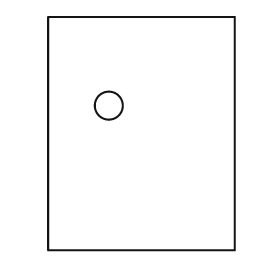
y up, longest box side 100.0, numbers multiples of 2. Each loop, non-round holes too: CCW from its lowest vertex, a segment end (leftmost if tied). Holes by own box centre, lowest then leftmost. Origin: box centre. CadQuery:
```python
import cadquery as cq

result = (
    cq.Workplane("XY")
    .moveTo(-40.0, -50.0)
    .lineTo(40.0, -50.0)
    .lineTo(40.0, 50.0)
    .lineTo(-40.0, 50.0)
    .close()
    .moveTo(-14.0, 12.0)
    .circle(6.0)
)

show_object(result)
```